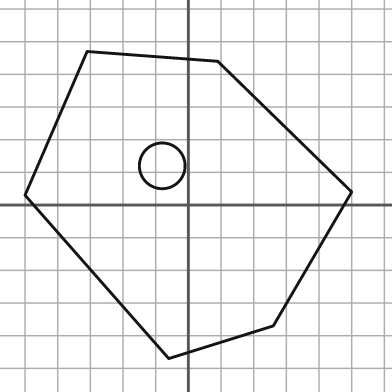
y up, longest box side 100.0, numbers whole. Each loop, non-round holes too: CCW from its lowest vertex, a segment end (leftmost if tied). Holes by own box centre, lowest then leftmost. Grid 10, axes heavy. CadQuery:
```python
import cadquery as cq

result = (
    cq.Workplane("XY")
    .moveTo(-6.0, -47.0)
    .lineTo(26.0, -37.0)
    .lineTo(50.0, 4.0)
    .lineTo(9.0, 44.0)
    .lineTo(-31.0, 47.0)
    .lineTo(-50.0, 3.0)
    .close()
    .moveTo(-8.0, 12.0)
    .circle(7.0)
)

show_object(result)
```